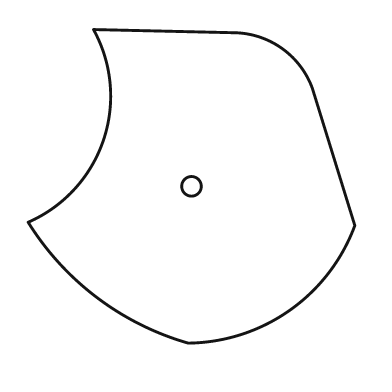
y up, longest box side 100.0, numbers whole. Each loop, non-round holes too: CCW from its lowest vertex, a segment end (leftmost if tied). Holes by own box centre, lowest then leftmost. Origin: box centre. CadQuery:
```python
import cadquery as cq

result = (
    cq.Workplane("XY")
    .moveTo(-1.0, -48.0)
    .threePointArc((30.0, -38.0), (50.0, -12.0))
    .lineTo(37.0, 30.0)
    .threePointArc((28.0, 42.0), (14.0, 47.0))
    .lineTo(-30.0, 48.0)
    .threePointArc((-27.0, 14.0), (-50.0, -11.0))
    .threePointArc((-29.0, -34.0), (-1.0, -48.0))
    .close()
    .moveTo(0.0, 0.0)
    .circle(3.0)
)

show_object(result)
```